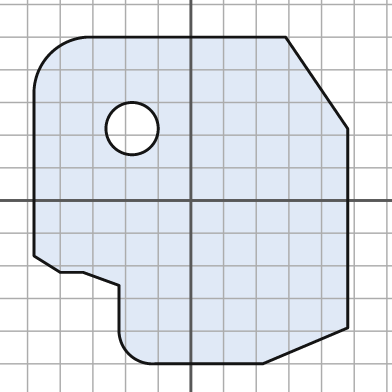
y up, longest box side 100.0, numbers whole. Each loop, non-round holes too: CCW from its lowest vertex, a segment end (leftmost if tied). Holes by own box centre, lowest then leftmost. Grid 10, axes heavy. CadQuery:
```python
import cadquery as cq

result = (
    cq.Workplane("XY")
    .moveTo(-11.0, -50.0)
    .lineTo(22.0, -50.0)
    .lineTo(48.0, -39.0)
    .lineTo(48.0, 22.0)
    .lineTo(29.0, 50.0)
    .lineTo(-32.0, 50.0)
    .threePointArc((-43.0, 45.0), (-48.0, 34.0))
    .lineTo(-48.0, -17.0)
    .lineTo(-40.0, -22.0)
    .lineTo(-33.0, -22.0)
    .lineTo(-22.0, -26.0)
    .lineTo(-22.0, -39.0)
    .threePointArc((-19.0, -47.0), (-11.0, -50.0))
    .close()
    .moveTo(-18.0, 22.0)
    .circle(8.0)
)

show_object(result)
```